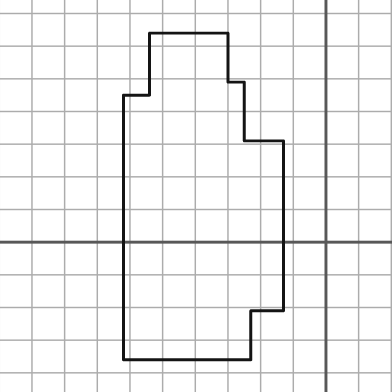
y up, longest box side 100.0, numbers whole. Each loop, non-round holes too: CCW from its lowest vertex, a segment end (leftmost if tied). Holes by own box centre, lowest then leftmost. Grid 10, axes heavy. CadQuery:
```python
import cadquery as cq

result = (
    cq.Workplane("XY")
    .moveTo(-62.0, -36.0)
    .lineTo(-23.0, -36.0)
    .lineTo(-23.0, -21.0)
    .lineTo(-13.0, -21.0)
    .lineTo(-13.0, 31.0)
    .lineTo(-25.0, 31.0)
    .lineTo(-25.0, 49.0)
    .lineTo(-30.0, 49.0)
    .lineTo(-30.0, 64.0)
    .lineTo(-54.0, 64.0)
    .lineTo(-54.0, 45.0)
    .lineTo(-62.0, 45.0)
    .close()
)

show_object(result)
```